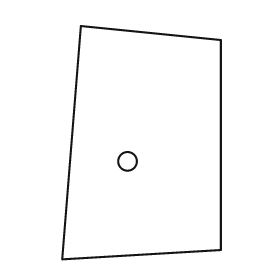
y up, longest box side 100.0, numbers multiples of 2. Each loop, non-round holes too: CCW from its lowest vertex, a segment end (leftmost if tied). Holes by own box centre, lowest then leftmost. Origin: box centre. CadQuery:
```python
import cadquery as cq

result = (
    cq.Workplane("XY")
    .moveTo(-34.0, -50.0)
    .lineTo(34.0, -46.0)
    .lineTo(34.0, 44.0)
    .lineTo(-26.0, 50.0)
    .close()
    .moveTo(-6.0, -8.0)
    .circle(4.0)
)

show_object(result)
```